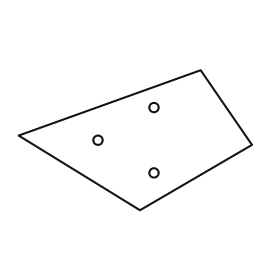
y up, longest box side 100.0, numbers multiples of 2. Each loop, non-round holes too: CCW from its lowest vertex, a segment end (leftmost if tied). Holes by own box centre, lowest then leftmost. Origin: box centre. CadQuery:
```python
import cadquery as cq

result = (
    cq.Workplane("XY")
    .moveTo(2.0, -30.0)
    .lineTo(50.0, -2.0)
    .lineTo(28.0, 30.0)
    .lineTo(-50.0, 2.0)
    .close()
    .moveTo(8.0, -14.0)
    .circle(2.0)
    .moveTo(-16.0, 0.0)
    .circle(2.0)
    .moveTo(8.0, 14.0)
    .circle(2.0)
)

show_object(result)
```